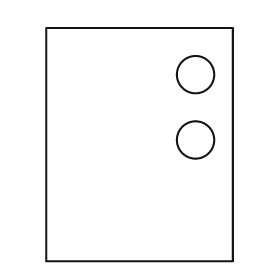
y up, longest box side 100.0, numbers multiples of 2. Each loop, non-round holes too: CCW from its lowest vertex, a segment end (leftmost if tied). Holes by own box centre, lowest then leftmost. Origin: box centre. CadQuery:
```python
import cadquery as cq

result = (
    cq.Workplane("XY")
    .moveTo(-40.0, -50.0)
    .lineTo(40.0, -50.0)
    .lineTo(40.0, 50.0)
    .lineTo(-40.0, 50.0)
    .close()
    .moveTo(24.0, 2.0)
    .circle(8.0)
    .moveTo(24.0, 30.0)
    .circle(8.0)
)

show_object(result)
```